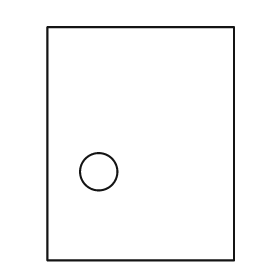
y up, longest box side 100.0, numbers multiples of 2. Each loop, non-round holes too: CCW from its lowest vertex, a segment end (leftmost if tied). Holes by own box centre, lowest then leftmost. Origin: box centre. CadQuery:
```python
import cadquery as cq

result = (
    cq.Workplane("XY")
    .moveTo(-40.0, -50.0)
    .lineTo(40.0, -50.0)
    .lineTo(40.0, 50.0)
    .lineTo(-40.0, 50.0)
    .close()
    .moveTo(-18.0, -12.0)
    .circle(8.0)
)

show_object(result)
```